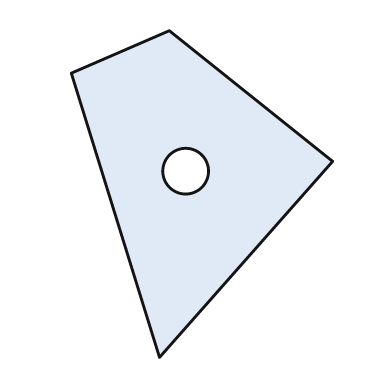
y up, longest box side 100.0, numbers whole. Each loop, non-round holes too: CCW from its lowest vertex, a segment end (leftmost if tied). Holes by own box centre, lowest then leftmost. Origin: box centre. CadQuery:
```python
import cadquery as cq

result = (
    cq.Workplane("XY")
    .moveTo(-13.0, -50.0)
    .lineTo(40.0, 10.0)
    .lineTo(-10.0, 50.0)
    .lineTo(-40.0, 37.0)
    .close()
    .moveTo(-5.0, 7.0)
    .circle(7.0)
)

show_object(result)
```